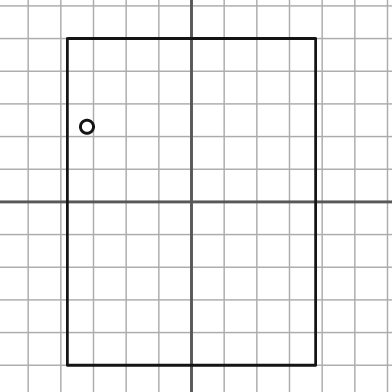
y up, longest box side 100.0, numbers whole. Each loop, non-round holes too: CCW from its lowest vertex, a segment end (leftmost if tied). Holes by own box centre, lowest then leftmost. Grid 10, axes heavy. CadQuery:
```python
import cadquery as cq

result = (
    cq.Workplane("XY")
    .moveTo(-38.0, -50.0)
    .lineTo(38.0, -50.0)
    .lineTo(38.0, 50.0)
    .lineTo(-38.0, 50.0)
    .close()
    .moveTo(-32.0, 23.0)
    .circle(2.0)
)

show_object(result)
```